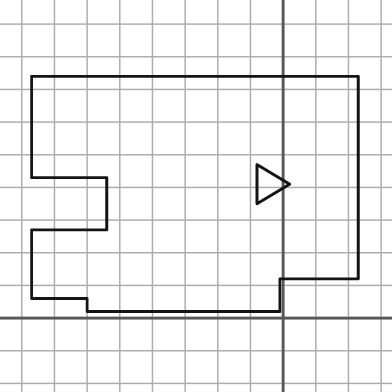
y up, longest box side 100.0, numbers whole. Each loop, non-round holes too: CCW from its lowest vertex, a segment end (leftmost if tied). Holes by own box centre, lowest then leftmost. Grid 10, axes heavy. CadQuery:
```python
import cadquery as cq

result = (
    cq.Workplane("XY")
    .moveTo(-60.0, 2.0)
    .lineTo(-1.0, 2.0)
    .lineTo(-1.0, 12.0)
    .lineTo(23.0, 12.0)
    .lineTo(23.0, 74.0)
    .lineTo(-77.0, 74.0)
    .lineTo(-77.0, 43.0)
    .lineTo(-54.0, 43.0)
    .lineTo(-54.0, 27.0)
    .lineTo(-77.0, 27.0)
    .lineTo(-77.0, 6.0)
    .lineTo(-60.0, 6.0)
    .close()
    .moveTo(-8.0, 35.0)
    .lineTo(2.0, 41.0)
    .lineTo(-8.0, 47.0)
    .close()
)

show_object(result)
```